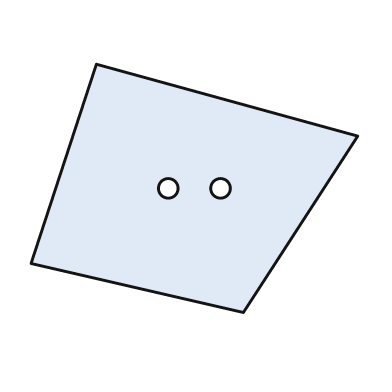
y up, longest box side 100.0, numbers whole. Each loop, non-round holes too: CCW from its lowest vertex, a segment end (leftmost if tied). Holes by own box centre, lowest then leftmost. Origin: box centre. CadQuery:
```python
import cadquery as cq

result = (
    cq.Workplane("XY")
    .moveTo(15.0, -38.0)
    .lineTo(50.0, 16.0)
    .lineTo(-30.0, 38.0)
    .lineTo(-50.0, -23.0)
    .close()
    .moveTo(-8.0, 0.0)
    .circle(3.0)
    .moveTo(8.0, 0.0)
    .circle(3.0)
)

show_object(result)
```